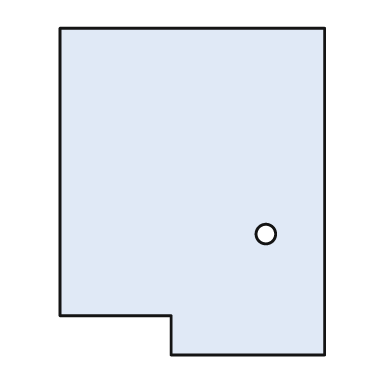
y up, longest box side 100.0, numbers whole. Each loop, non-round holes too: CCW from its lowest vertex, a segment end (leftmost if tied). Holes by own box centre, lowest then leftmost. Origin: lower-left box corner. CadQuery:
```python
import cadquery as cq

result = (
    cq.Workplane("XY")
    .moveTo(34.0, 0.0)
    .lineTo(81.0, 0.0)
    .lineTo(81.0, 100.0)
    .lineTo(0.0, 100.0)
    .lineTo(0.0, 12.0)
    .lineTo(34.0, 12.0)
    .close()
    .moveTo(63.0, 37.0)
    .circle(3.0)
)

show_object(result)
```